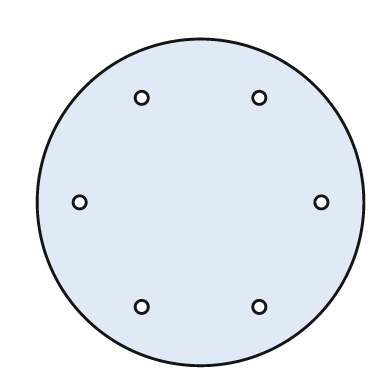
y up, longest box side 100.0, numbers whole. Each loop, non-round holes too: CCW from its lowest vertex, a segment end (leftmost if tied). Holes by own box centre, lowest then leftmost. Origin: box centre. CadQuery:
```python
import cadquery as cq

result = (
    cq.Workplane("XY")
    .moveTo(0.0, 0.0)
    .circle(50.0)
    .moveTo(-18.0, -32.0)
    .circle(2.0)
    .moveTo(18.0, -32.0)
    .circle(2.0)
    .moveTo(-37.0, 0.0)
    .circle(2.0)
    .moveTo(37.0, 0.0)
    .circle(2.0)
    .moveTo(-18.0, 32.0)
    .circle(2.0)
    .moveTo(18.0, 32.0)
    .circle(2.0)
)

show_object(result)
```